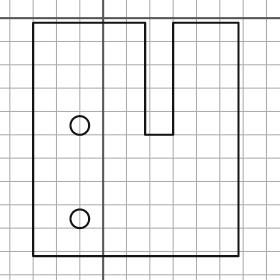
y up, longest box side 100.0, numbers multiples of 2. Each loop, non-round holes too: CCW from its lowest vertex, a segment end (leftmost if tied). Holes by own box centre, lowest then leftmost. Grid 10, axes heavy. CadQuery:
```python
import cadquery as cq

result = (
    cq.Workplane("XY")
    .moveTo(-30.0, -102.0)
    .lineTo(58.0, -102.0)
    .lineTo(58.0, -2.0)
    .lineTo(30.0, -2.0)
    .lineTo(30.0, -50.0)
    .lineTo(18.0, -50.0)
    .lineTo(18.0, -2.0)
    .lineTo(-30.0, -2.0)
    .close()
    .moveTo(-10.0, -86.0)
    .circle(4.0)
    .moveTo(-10.0, -46.0)
    .circle(4.0)
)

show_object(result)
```